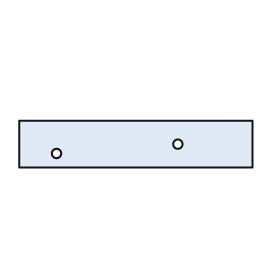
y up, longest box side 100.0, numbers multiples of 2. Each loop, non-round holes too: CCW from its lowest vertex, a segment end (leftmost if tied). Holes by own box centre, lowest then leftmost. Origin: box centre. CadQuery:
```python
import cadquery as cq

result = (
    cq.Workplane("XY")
    .moveTo(-50.0, -10.0)
    .lineTo(50.0, -10.0)
    .lineTo(50.0, 10.0)
    .lineTo(-50.0, 10.0)
    .close()
    .moveTo(-34.0, -4.0)
    .circle(2.0)
    .moveTo(18.0, 0.0)
    .circle(2.0)
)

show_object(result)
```